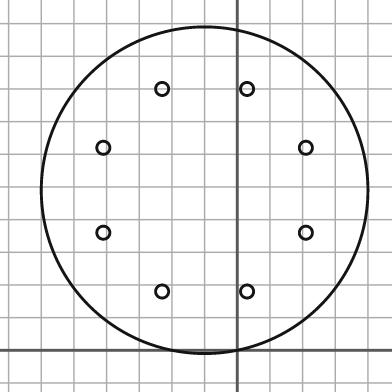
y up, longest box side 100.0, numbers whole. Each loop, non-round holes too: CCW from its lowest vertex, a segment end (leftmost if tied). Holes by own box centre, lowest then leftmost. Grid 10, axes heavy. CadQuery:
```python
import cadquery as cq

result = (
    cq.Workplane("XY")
    .moveTo(-10.0, 49.0)
    .circle(50.0)
    .moveTo(-23.0, 18.0)
    .circle(2.0)
    .moveTo(3.0, 18.0)
    .circle(2.0)
    .moveTo(-41.0, 36.0)
    .circle(2.0)
    .moveTo(21.0, 36.0)
    .circle(2.0)
    .moveTo(-41.0, 62.0)
    .circle(2.0)
    .moveTo(21.0, 62.0)
    .circle(2.0)
    .moveTo(-23.0, 80.0)
    .circle(2.0)
    .moveTo(3.0, 80.0)
    .circle(2.0)
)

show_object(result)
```